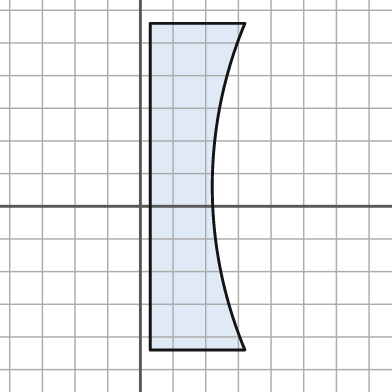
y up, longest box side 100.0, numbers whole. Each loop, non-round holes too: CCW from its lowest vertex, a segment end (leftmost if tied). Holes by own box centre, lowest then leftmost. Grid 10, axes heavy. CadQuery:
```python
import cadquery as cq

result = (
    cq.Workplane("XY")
    .moveTo(3.0, -44.0)
    .lineTo(32.0, -44.0)
    .threePointArc((22.0, 6.0), (32.0, 56.0))
    .lineTo(3.0, 56.0)
    .close()
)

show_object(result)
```